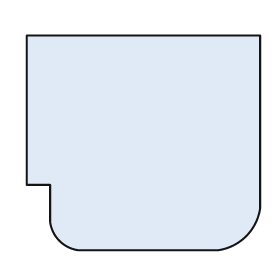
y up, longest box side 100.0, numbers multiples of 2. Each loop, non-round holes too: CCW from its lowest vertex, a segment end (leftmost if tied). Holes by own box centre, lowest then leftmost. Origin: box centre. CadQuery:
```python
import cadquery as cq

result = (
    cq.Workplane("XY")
    .moveTo(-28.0, -46.0)
    .lineTo(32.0, -46.0)
    .threePointArc((44.0, -40.0), (50.0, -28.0))
    .lineTo(50.0, 46.0)
    .lineTo(-50.0, 46.0)
    .lineTo(-50.0, -18.0)
    .lineTo(-40.0, -18.0)
    .lineTo(-40.0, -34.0)
    .threePointArc((-36.0, -42.0), (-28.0, -46.0))
    .close()
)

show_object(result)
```